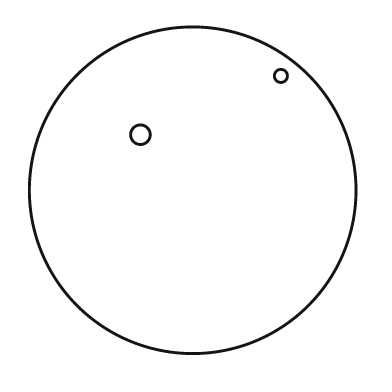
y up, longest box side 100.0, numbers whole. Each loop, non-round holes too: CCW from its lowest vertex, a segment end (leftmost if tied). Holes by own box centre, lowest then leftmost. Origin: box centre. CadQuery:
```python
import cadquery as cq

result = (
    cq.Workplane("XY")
    .moveTo(0.0, 0.0)
    .circle(50.0)
    .moveTo(-16.0, 17.0)
    .circle(3.0)
    .moveTo(27.0, 35.0)
    .circle(2.0)
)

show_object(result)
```